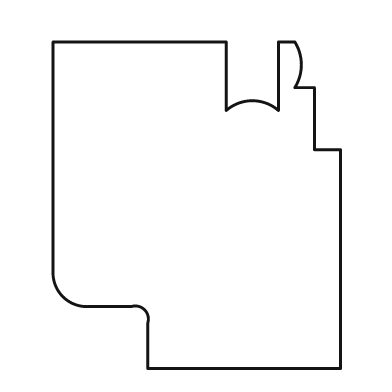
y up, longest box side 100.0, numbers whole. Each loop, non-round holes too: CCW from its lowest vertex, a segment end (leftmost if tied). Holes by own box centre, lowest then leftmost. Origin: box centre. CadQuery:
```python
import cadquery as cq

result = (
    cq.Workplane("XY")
    .moveTo(-15.0, -50.0)
    .lineTo(44.0, -50.0)
    .lineTo(44.0, 17.0)
    .lineTo(36.0, 17.0)
    .lineTo(36.0, 36.0)
    .lineTo(30.0, 36.0)
    .threePointArc((32.0, 43.0), (30.0, 50.0))
    .lineTo(25.0, 50.0)
    .lineTo(25.0, 29.0)
    .threePointArc((17.0, 32.0), (9.0, 29.0))
    .lineTo(9.0, 50.0)
    .lineTo(-44.0, 50.0)
    .lineTo(-44.0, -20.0)
    .threePointArc((-41.0, -28.0), (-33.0, -31.0))
    .lineTo(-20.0, -31.0)
    .threePointArc((-16.0, -32.0), (-15.0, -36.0))
    .close()
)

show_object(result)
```